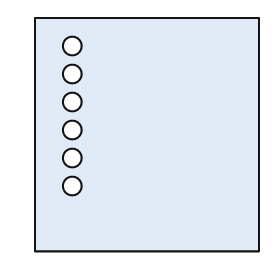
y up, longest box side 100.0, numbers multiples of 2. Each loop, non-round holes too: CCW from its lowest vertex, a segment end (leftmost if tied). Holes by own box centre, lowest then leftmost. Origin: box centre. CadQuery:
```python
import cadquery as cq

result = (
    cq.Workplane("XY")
    .moveTo(-48.0, -50.0)
    .lineTo(48.0, -50.0)
    .lineTo(48.0, 50.0)
    .lineTo(-48.0, 50.0)
    .close()
    .moveTo(-32.0, -22.0)
    .circle(4.0)
    .moveTo(-32.0, -10.0)
    .circle(4.0)
    .moveTo(-32.0, 2.0)
    .circle(4.0)
    .moveTo(-32.0, 14.0)
    .circle(4.0)
    .moveTo(-32.0, 26.0)
    .circle(4.0)
    .moveTo(-32.0, 38.0)
    .circle(4.0)
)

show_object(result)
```